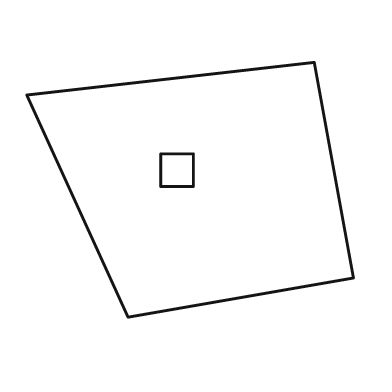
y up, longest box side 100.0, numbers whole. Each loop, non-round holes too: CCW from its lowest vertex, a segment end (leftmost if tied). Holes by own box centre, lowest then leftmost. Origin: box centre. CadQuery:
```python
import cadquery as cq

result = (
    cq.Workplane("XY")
    .moveTo(-19.0, -39.0)
    .lineTo(50.0, -27.0)
    .lineTo(38.0, 39.0)
    .lineTo(-50.0, 29.0)
    .close()
    .moveTo(-9.0, 1.0)
    .lineTo(1.0, 1.0)
    .lineTo(1.0, 11.0)
    .lineTo(-9.0, 11.0)
    .close()
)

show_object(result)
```